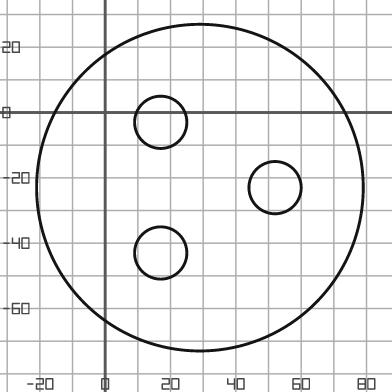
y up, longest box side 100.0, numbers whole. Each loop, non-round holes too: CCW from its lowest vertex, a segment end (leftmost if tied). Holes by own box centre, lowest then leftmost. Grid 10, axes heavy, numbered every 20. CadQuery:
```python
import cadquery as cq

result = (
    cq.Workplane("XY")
    .moveTo(29.0, -23.0)
    .circle(50.0)
    .moveTo(17.0, -43.0)
    .circle(8.0)
    .moveTo(52.0, -23.0)
    .circle(8.0)
    .moveTo(17.0, -3.0)
    .circle(8.0)
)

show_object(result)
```